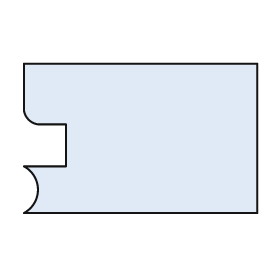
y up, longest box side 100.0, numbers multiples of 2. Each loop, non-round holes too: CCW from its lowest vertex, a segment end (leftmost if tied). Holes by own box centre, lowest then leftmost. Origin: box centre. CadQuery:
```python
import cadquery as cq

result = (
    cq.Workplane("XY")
    .moveTo(-50.0, -32.0)
    .lineTo(50.0, -32.0)
    .lineTo(50.0, 32.0)
    .lineTo(-50.0, 32.0)
    .lineTo(-50.0, 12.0)
    .threePointArc((-48.0, 8.0), (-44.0, 6.0))
    .lineTo(-32.0, 6.0)
    .lineTo(-32.0, -12.0)
    .lineTo(-50.0, -12.0)
    .threePointArc((-44.0, -22.0), (-50.0, -32.0))
    .close()
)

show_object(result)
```